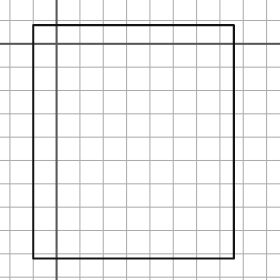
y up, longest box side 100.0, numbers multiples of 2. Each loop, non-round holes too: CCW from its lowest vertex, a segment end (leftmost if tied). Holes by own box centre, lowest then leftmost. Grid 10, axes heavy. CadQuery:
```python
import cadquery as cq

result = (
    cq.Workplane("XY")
    .moveTo(-10.0, -92.0)
    .lineTo(76.0, -92.0)
    .lineTo(76.0, 8.0)
    .lineTo(-10.0, 8.0)
    .close()
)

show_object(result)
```